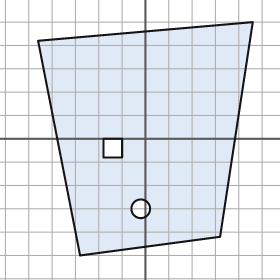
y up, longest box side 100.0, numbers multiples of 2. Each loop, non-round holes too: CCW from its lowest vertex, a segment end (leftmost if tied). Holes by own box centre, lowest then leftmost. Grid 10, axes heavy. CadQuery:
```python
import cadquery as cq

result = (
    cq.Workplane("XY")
    .moveTo(-28.0, -50.0)
    .lineTo(32.0, -42.0)
    .lineTo(46.0, 50.0)
    .lineTo(-46.0, 42.0)
    .close()
    .moveTo(-2.0, -30.0)
    .circle(4.0)
    .moveTo(-18.0, -8.0)
    .lineTo(-10.0, -8.0)
    .lineTo(-10.0, 0.0)
    .lineTo(-18.0, 0.0)
    .close()
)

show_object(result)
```